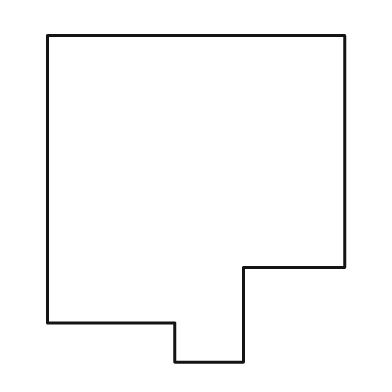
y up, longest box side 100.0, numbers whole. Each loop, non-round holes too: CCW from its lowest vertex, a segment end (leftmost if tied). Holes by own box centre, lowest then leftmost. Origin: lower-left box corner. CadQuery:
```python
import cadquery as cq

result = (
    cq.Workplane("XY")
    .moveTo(39.0, 0.0)
    .lineTo(60.0, 0.0)
    .lineTo(60.0, 29.0)
    .lineTo(91.0, 29.0)
    .lineTo(91.0, 100.0)
    .lineTo(0.0, 100.0)
    .lineTo(0.0, 12.0)
    .lineTo(39.0, 12.0)
    .close()
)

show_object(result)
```